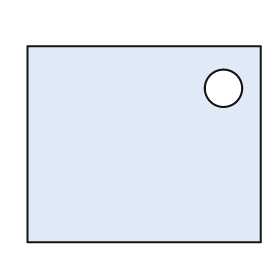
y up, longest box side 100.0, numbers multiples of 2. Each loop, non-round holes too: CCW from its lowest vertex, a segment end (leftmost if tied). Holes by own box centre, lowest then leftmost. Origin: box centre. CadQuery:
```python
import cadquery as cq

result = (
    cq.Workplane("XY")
    .moveTo(-50.0, -42.0)
    .lineTo(50.0, -42.0)
    .lineTo(50.0, 42.0)
    .lineTo(-50.0, 42.0)
    .close()
    .moveTo(34.0, 24.0)
    .circle(8.0)
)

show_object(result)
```